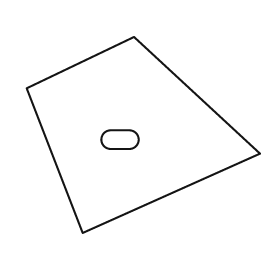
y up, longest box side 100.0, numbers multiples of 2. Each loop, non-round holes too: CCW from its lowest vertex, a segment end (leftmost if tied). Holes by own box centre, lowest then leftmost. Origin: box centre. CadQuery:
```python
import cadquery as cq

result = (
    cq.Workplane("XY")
    .moveTo(-26.0, -42.0)
    .lineTo(50.0, -8.0)
    .lineTo(-4.0, 42.0)
    .lineTo(-50.0, 20.0)
    .close()
    .moveTo(-14.0, -6.0)
    .lineTo(-6.0, -6.0)
    .threePointArc((-2.0, -2.0), (-6.0, 2.0))
    .lineTo(-14.0, 2.0)
    .threePointArc((-18.0, -2.0), (-14.0, -6.0))
    .close()
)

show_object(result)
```